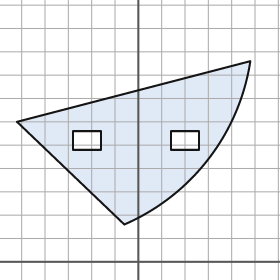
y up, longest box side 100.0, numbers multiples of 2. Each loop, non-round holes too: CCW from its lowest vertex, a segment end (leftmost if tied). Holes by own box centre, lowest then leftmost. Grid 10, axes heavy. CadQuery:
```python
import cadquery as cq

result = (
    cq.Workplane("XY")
    .moveTo(-6.0, 16.0)
    .threePointArc((30.0, 44.0), (48.0, 86.0))
    .lineTo(-52.0, 60.0)
    .close()
    .moveTo(-28.0, 48.0)
    .lineTo(-16.0, 48.0)
    .lineTo(-16.0, 56.0)
    .lineTo(-28.0, 56.0)
    .close()
    .moveTo(14.0, 48.0)
    .lineTo(26.0, 48.0)
    .lineTo(26.0, 56.0)
    .lineTo(14.0, 56.0)
    .close()
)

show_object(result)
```